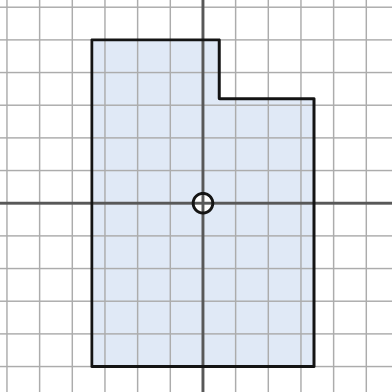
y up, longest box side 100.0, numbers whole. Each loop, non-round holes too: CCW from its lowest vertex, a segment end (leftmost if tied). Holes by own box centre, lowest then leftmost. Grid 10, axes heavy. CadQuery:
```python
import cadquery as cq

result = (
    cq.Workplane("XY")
    .moveTo(-34.0, -50.0)
    .lineTo(34.0, -50.0)
    .lineTo(34.0, 32.0)
    .lineTo(5.0, 32.0)
    .lineTo(5.0, 50.0)
    .lineTo(-34.0, 50.0)
    .close()
    .moveTo(0.0, 0.0)
    .circle(3.0)
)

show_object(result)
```